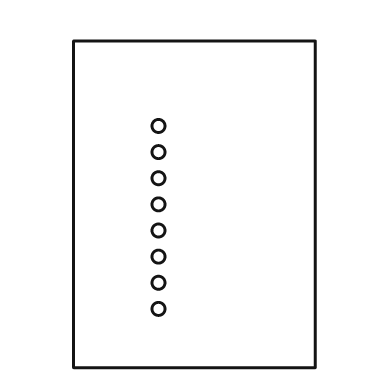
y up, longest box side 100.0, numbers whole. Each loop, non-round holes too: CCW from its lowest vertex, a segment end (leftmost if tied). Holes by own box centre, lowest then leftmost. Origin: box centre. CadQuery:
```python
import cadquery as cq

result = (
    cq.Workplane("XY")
    .moveTo(-37.0, -50.0)
    .lineTo(37.0, -50.0)
    .lineTo(37.0, 50.0)
    .lineTo(-37.0, 50.0)
    .close()
    .moveTo(-11.0, -32.0)
    .circle(2.0)
    .moveTo(-11.0, -24.0)
    .circle(2.0)
    .moveTo(-11.0, -16.0)
    .circle(2.0)
    .moveTo(-11.0, -8.0)
    .circle(2.0)
    .moveTo(-11.0, 0.0)
    .circle(2.0)
    .moveTo(-11.0, 8.0)
    .circle(2.0)
    .moveTo(-11.0, 16.0)
    .circle(2.0)
    .moveTo(-11.0, 24.0)
    .circle(2.0)
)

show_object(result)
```